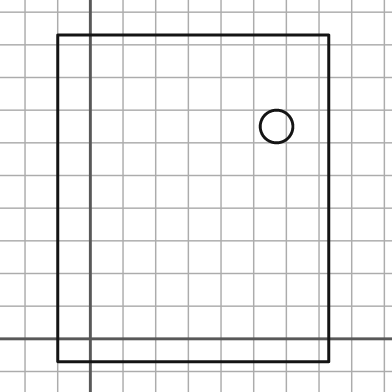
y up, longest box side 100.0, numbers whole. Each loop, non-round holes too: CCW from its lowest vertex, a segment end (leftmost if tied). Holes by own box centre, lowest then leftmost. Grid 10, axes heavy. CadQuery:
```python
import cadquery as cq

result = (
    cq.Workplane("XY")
    .moveTo(-10.0, -7.0)
    .lineTo(73.0, -7.0)
    .lineTo(73.0, 93.0)
    .lineTo(-10.0, 93.0)
    .close()
    .moveTo(57.0, 65.0)
    .circle(5.0)
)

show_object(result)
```